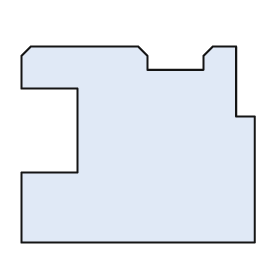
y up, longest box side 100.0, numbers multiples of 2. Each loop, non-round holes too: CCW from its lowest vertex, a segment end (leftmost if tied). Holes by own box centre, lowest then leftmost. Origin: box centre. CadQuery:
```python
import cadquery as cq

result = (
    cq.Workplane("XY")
    .moveTo(-50.0, -42.0)
    .lineTo(50.0, -42.0)
    .lineTo(50.0, 12.0)
    .lineTo(42.0, 12.0)
    .lineTo(42.0, 42.0)
    .lineTo(32.0, 42.0)
    .lineTo(28.0, 38.0)
    .lineTo(28.0, 32.0)
    .lineTo(4.0, 32.0)
    .lineTo(4.0, 38.0)
    .lineTo(0.0, 42.0)
    .lineTo(-46.0, 42.0)
    .lineTo(-50.0, 38.0)
    .lineTo(-50.0, 24.0)
    .lineTo(-26.0, 24.0)
    .lineTo(-26.0, -12.0)
    .lineTo(-50.0, -12.0)
    .close()
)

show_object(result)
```